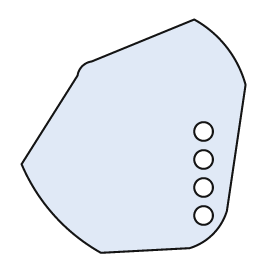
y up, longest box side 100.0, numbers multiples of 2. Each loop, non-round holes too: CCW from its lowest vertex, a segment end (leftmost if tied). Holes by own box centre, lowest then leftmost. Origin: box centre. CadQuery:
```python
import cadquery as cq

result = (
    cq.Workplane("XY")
    .moveTo(-14.0, -50.0)
    .lineTo(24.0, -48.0)
    .threePointArc((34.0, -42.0), (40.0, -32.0))
    .lineTo(48.0, 22.0)
    .threePointArc((40.0, 38.0), (26.0, 50.0))
    .lineTo(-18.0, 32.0)
    .threePointArc((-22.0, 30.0), (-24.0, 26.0))
    .lineTo(-48.0, -12.0)
    .threePointArc((-34.0, -34.0), (-14.0, -50.0))
    .close()
    .moveTo(30.0, -34.0)
    .circle(4.0)
    .moveTo(30.0, -22.0)
    .circle(4.0)
    .moveTo(30.0, -10.0)
    .circle(4.0)
    .moveTo(30.0, 2.0)
    .circle(4.0)
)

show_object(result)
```